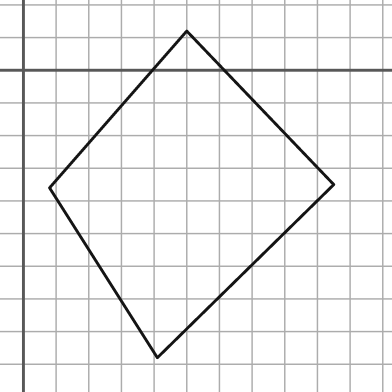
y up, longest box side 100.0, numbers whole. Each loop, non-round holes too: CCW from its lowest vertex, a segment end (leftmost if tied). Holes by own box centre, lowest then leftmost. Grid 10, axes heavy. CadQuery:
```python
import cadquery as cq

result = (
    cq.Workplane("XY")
    .moveTo(41.0, -88.0)
    .lineTo(95.0, -35.0)
    .lineTo(50.0, 12.0)
    .lineTo(8.0, -36.0)
    .close()
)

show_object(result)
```